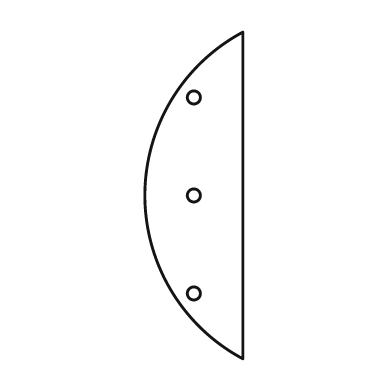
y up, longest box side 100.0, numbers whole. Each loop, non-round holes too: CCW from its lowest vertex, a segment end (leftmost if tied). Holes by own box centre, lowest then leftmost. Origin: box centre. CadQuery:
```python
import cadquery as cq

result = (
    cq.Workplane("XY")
    .moveTo(15.0, -50.0)
    .lineTo(15.0, 50.0)
    .threePointArc((-15.0, 0.0), (15.0, -50.0))
    .close()
    .moveTo(0.0, -30.0)
    .circle(2.0)
    .moveTo(0.0, 0.0)
    .circle(2.0)
    .moveTo(0.0, 30.0)
    .circle(2.0)
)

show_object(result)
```